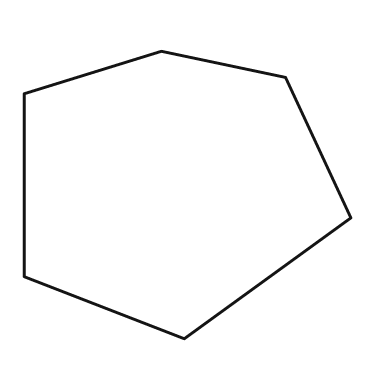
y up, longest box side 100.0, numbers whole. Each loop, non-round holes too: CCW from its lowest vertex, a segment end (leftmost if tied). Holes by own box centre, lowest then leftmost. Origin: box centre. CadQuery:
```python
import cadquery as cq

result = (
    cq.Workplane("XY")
    .moveTo(-1.0, -44.0)
    .lineTo(50.0, -7.0)
    .lineTo(30.0, 36.0)
    .lineTo(-8.0, 44.0)
    .lineTo(-50.0, 31.0)
    .lineTo(-50.0, -25.0)
    .close()
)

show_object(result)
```